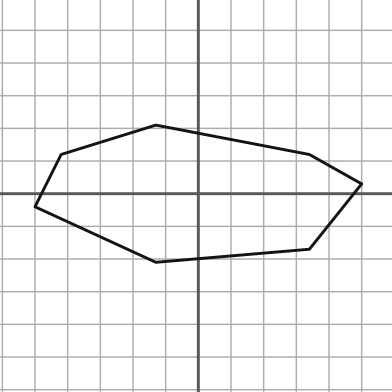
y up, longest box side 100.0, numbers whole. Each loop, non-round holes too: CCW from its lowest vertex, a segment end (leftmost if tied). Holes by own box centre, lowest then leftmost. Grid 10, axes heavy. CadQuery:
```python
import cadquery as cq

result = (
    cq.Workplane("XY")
    .moveTo(-13.0, -21.0)
    .lineTo(34.0, -17.0)
    .lineTo(50.0, 3.0)
    .lineTo(34.0, 12.0)
    .lineTo(-13.0, 21.0)
    .lineTo(-42.0, 12.0)
    .lineTo(-50.0, -4.0)
    .close()
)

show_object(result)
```